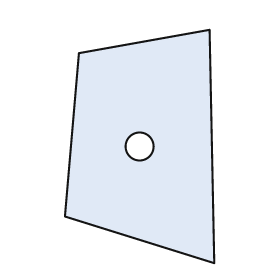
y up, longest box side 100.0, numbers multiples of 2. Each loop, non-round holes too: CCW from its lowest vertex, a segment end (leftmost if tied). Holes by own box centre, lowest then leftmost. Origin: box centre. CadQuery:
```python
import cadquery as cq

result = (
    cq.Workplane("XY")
    .moveTo(32.0, -50.0)
    .lineTo(30.0, 50.0)
    .lineTo(-26.0, 40.0)
    .lineTo(-32.0, -30.0)
    .close()
    .moveTo(0.0, 0.0)
    .circle(6.0)
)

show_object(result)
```